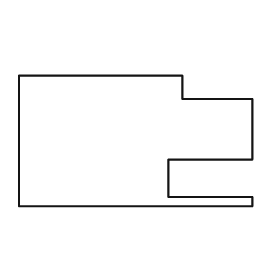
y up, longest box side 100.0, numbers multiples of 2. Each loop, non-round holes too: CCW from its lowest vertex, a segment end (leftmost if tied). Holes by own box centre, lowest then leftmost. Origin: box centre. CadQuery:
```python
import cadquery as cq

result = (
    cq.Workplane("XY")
    .moveTo(-50.0, -28.0)
    .lineTo(50.0, -28.0)
    .lineTo(50.0, -24.0)
    .lineTo(14.0, -24.0)
    .lineTo(14.0, -8.0)
    .lineTo(50.0, -8.0)
    .lineTo(50.0, 18.0)
    .lineTo(20.0, 18.0)
    .lineTo(20.0, 28.0)
    .lineTo(-50.0, 28.0)
    .close()
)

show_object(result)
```